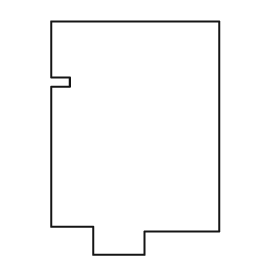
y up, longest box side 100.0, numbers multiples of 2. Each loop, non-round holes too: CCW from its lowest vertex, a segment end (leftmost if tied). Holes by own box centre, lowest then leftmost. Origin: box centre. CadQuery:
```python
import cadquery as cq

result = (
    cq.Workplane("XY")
    .moveTo(-18.0, -50.0)
    .lineTo(4.0, -50.0)
    .lineTo(4.0, -40.0)
    .lineTo(36.0, -40.0)
    .lineTo(36.0, 50.0)
    .lineTo(-36.0, 50.0)
    .lineTo(-36.0, 26.0)
    .lineTo(-28.0, 26.0)
    .lineTo(-28.0, 22.0)
    .lineTo(-36.0, 22.0)
    .lineTo(-36.0, -38.0)
    .lineTo(-18.0, -38.0)
    .close()
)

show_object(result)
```